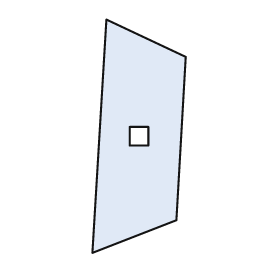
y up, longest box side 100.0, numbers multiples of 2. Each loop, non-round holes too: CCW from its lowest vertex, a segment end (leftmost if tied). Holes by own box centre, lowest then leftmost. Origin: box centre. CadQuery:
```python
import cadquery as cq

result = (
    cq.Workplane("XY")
    .moveTo(-20.0, -50.0)
    .lineTo(16.0, -36.0)
    .lineTo(20.0, 34.0)
    .lineTo(-14.0, 50.0)
    .close()
    .moveTo(-4.0, -4.0)
    .lineTo(4.0, -4.0)
    .lineTo(4.0, 4.0)
    .lineTo(-4.0, 4.0)
    .close()
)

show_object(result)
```